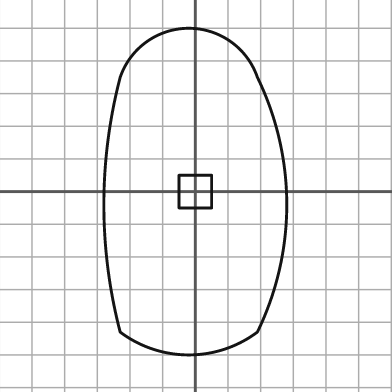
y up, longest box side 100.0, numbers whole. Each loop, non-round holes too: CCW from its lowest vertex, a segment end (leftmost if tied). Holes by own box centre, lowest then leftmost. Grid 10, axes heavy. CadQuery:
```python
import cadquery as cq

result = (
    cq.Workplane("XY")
    .moveTo(-23.0, -43.0)
    .threePointArc((-2.0, -50.0), (19.0, -43.0))
    .threePointArc((28.0, -4.0), (19.0, 35.0))
    .threePointArc((-2.0, 50.0), (-23.0, 35.0))
    .threePointArc((-28.0, -4.0), (-23.0, -43.0))
    .close()
    .moveTo(-5.0, -5.0)
    .lineTo(5.0, -5.0)
    .lineTo(5.0, 5.0)
    .lineTo(-5.0, 5.0)
    .close()
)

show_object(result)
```